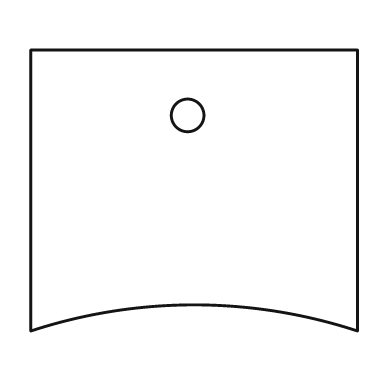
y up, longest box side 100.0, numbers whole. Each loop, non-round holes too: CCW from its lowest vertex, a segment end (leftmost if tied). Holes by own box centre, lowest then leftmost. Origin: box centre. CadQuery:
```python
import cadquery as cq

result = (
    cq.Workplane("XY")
    .moveTo(-50.0, -43.0)
    .threePointArc((0.0, -35.0), (50.0, -43.0))
    .lineTo(50.0, 43.0)
    .lineTo(-50.0, 43.0)
    .close()
    .moveTo(-2.0, 23.0)
    .circle(5.0)
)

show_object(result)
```